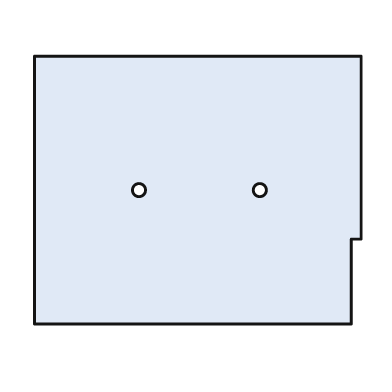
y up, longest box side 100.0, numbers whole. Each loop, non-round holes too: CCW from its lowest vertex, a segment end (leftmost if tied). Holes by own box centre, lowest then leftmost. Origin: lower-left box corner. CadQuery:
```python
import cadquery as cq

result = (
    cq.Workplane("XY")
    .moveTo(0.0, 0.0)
    .lineTo(97.0, 0.0)
    .lineTo(97.0, 26.0)
    .lineTo(100.0, 26.0)
    .lineTo(100.0, 82.0)
    .lineTo(0.0, 82.0)
    .close()
    .moveTo(32.0, 41.0)
    .circle(2.0)
    .moveTo(69.0, 41.0)
    .circle(2.0)
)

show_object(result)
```